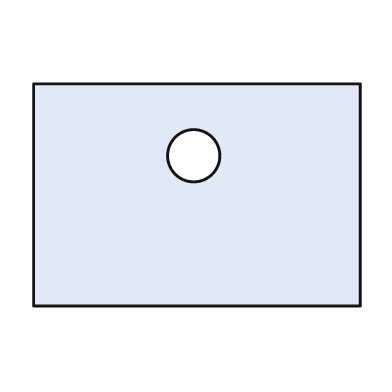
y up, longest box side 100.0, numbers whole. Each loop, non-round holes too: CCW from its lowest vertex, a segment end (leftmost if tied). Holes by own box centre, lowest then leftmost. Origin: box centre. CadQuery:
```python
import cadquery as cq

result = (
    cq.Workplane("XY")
    .moveTo(-50.0, -34.0)
    .lineTo(50.0, -34.0)
    .lineTo(50.0, 34.0)
    .lineTo(-50.0, 34.0)
    .close()
    .moveTo(-1.0, 12.0)
    .circle(8.0)
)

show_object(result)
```